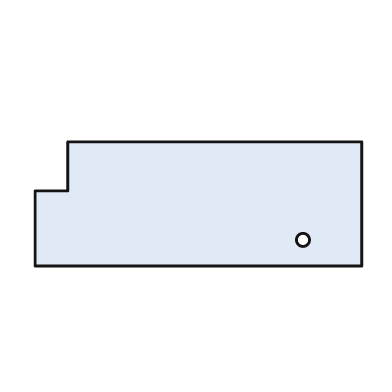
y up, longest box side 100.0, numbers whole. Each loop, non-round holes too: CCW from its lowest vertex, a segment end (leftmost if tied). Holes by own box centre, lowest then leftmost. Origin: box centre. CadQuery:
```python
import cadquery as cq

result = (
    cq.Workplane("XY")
    .moveTo(-50.0, -19.0)
    .lineTo(50.0, -19.0)
    .lineTo(50.0, 19.0)
    .lineTo(-40.0, 19.0)
    .lineTo(-40.0, 4.0)
    .lineTo(-50.0, 4.0)
    .close()
    .moveTo(32.0, -11.0)
    .circle(2.0)
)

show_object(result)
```